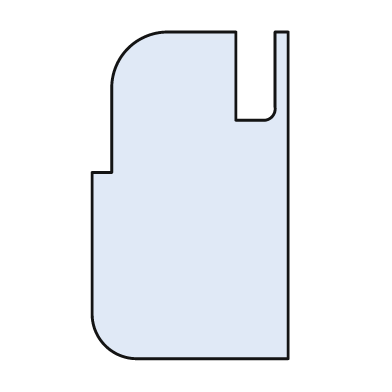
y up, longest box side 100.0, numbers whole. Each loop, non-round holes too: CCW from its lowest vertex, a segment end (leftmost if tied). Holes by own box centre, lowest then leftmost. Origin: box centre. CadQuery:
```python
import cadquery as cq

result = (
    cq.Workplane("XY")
    .moveTo(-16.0, -50.0)
    .lineTo(30.0, -50.0)
    .lineTo(30.0, 50.0)
    .lineTo(26.0, 50.0)
    .lineTo(26.0, 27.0)
    .threePointArc((25.0, 24.0), (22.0, 23.0))
    .lineTo(14.0, 23.0)
    .lineTo(14.0, 50.0)
    .lineTo(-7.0, 50.0)
    .threePointArc((-19.0, 45.0), (-24.0, 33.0))
    .lineTo(-24.0, 7.0)
    .lineTo(-30.0, 7.0)
    .lineTo(-30.0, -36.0)
    .threePointArc((-26.0, -46.0), (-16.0, -50.0))
    .close()
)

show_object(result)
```